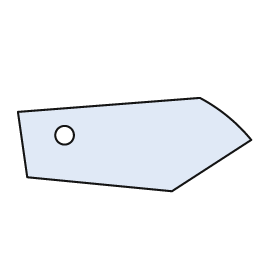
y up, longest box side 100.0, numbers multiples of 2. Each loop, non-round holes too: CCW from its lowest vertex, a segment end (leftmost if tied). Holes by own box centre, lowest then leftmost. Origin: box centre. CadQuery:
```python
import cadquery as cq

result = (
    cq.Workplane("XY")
    .moveTo(16.0, -20.0)
    .lineTo(50.0, 2.0)
    .threePointArc((40.0, 12.0), (28.0, 20.0))
    .lineTo(-50.0, 14.0)
    .lineTo(-46.0, -14.0)
    .close()
    .moveTo(-30.0, 4.0)
    .circle(4.0)
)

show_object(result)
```